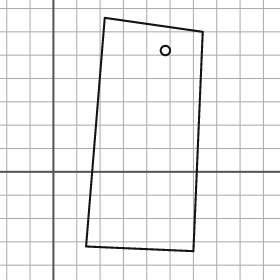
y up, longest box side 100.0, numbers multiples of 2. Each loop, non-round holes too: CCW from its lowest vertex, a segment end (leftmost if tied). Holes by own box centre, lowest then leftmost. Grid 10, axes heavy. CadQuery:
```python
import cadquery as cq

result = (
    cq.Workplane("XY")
    .moveTo(60.0, -34.0)
    .lineTo(64.0, 60.0)
    .lineTo(22.0, 66.0)
    .lineTo(14.0, -32.0)
    .close()
    .moveTo(48.0, 52.0)
    .circle(2.0)
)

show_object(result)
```